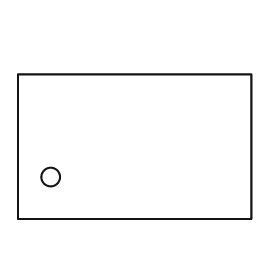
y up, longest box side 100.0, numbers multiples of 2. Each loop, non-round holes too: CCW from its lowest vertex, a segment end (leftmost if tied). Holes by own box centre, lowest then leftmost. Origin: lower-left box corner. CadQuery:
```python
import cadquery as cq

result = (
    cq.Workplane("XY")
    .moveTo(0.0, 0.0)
    .lineTo(100.0, 0.0)
    .lineTo(100.0, 62.0)
    .lineTo(0.0, 62.0)
    .close()
    .moveTo(14.0, 18.0)
    .circle(4.0)
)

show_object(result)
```